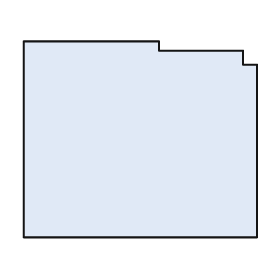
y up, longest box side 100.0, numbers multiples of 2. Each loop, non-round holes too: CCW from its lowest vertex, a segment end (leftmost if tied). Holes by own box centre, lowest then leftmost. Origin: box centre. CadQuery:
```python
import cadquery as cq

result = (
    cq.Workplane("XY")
    .moveTo(-50.0, -42.0)
    .lineTo(50.0, -42.0)
    .lineTo(50.0, 32.0)
    .lineTo(44.0, 32.0)
    .lineTo(44.0, 38.0)
    .lineTo(8.0, 38.0)
    .lineTo(8.0, 42.0)
    .lineTo(-50.0, 42.0)
    .close()
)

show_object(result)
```